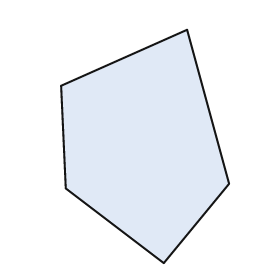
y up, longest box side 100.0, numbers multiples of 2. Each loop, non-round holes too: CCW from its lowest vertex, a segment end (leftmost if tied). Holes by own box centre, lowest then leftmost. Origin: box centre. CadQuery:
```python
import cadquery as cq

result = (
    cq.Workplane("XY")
    .moveTo(8.0, -50.0)
    .lineTo(36.0, -16.0)
    .lineTo(18.0, 50.0)
    .lineTo(-36.0, 26.0)
    .lineTo(-34.0, -18.0)
    .close()
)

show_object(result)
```